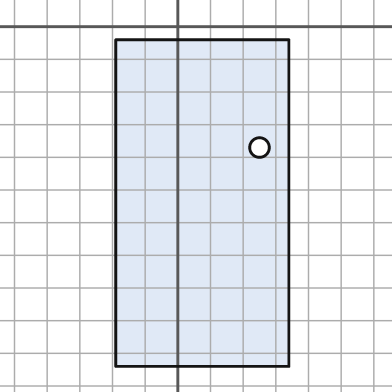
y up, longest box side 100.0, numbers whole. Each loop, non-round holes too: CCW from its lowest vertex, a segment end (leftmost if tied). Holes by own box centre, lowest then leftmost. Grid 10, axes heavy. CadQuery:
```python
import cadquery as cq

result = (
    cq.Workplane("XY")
    .moveTo(-19.0, -104.0)
    .lineTo(34.0, -104.0)
    .lineTo(34.0, -4.0)
    .lineTo(-19.0, -4.0)
    .close()
    .moveTo(25.0, -37.0)
    .circle(3.0)
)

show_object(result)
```